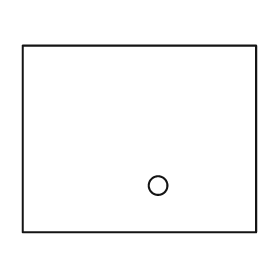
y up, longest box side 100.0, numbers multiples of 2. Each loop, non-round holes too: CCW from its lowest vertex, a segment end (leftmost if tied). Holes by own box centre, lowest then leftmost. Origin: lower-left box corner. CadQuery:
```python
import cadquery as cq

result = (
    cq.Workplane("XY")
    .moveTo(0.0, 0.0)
    .lineTo(100.0, 0.0)
    .lineTo(100.0, 80.0)
    .lineTo(0.0, 80.0)
    .close()
    .moveTo(58.0, 20.0)
    .circle(4.0)
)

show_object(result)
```